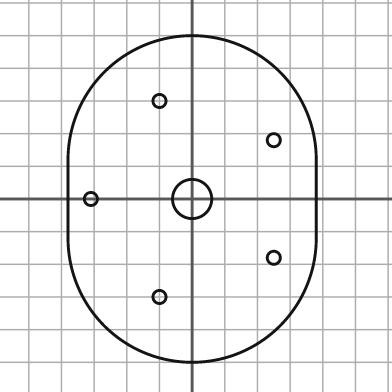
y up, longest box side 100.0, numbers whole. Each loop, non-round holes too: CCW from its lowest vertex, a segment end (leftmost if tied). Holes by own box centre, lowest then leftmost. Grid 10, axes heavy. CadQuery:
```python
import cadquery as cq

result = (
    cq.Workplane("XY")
    .moveTo(-38.0, -12.0)
    .threePointArc((0.0, -50.0), (38.0, -12.0))
    .lineTo(38.0, 12.0)
    .threePointArc((0.0, 50.0), (-38.0, 12.0))
    .close()
    .moveTo(-10.0, -30.0)
    .circle(2.0)
    .moveTo(25.0, -18.0)
    .circle(2.0)
    .moveTo(-31.0, 0.0)
    .circle(2.0)
    .moveTo(0.0, 0.0)
    .circle(6.0)
    .moveTo(25.0, 18.0)
    .circle(2.0)
    .moveTo(-10.0, 30.0)
    .circle(2.0)
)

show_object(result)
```